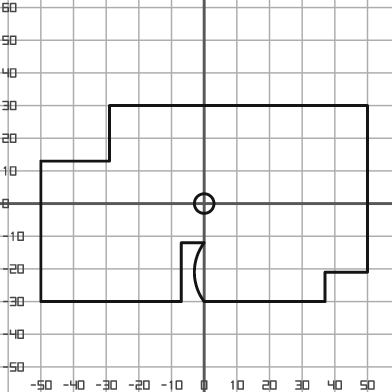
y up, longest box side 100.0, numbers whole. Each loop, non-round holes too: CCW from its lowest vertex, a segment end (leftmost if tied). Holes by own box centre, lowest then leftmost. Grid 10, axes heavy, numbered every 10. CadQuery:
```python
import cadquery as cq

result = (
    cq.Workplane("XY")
    .moveTo(-50.0, -30.0)
    .lineTo(-7.0, -30.0)
    .lineTo(-7.0, -12.0)
    .lineTo(0.0, -12.0)
    .threePointArc((-3.0, -21.0), (0.0, -30.0))
    .lineTo(37.0, -30.0)
    .lineTo(37.0, -21.0)
    .lineTo(50.0, -21.0)
    .lineTo(50.0, 30.0)
    .lineTo(-29.0, 30.0)
    .lineTo(-29.0, 13.0)
    .lineTo(-50.0, 13.0)
    .close()
    .moveTo(0.0, 0.0)
    .circle(3.0)
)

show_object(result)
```